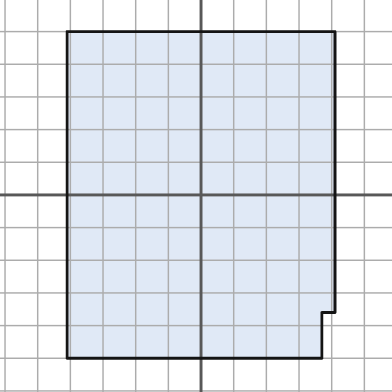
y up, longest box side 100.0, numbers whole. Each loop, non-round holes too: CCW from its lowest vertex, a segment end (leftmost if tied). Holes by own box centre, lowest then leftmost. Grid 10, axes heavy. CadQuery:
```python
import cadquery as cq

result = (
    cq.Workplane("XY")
    .moveTo(-41.0, -50.0)
    .lineTo(37.0, -50.0)
    .lineTo(37.0, -36.0)
    .lineTo(41.0, -36.0)
    .lineTo(41.0, 50.0)
    .lineTo(-41.0, 50.0)
    .close()
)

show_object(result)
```